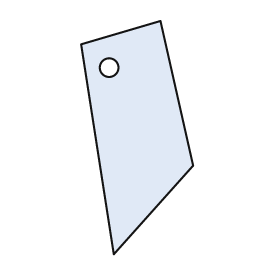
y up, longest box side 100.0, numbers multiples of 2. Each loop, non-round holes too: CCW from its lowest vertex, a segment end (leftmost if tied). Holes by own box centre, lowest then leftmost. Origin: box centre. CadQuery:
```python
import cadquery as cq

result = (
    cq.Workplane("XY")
    .moveTo(-10.0, -50.0)
    .lineTo(24.0, -12.0)
    .lineTo(10.0, 50.0)
    .lineTo(-24.0, 40.0)
    .close()
    .moveTo(-12.0, 30.0)
    .circle(4.0)
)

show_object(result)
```